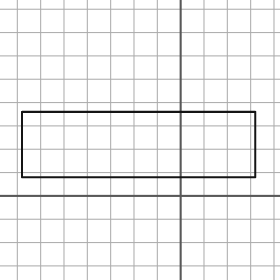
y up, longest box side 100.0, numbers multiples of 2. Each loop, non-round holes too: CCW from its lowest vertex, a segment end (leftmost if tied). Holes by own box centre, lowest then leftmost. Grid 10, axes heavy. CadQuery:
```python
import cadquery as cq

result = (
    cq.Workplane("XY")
    .moveTo(-68.0, 8.0)
    .lineTo(32.0, 8.0)
    .lineTo(32.0, 36.0)
    .lineTo(-68.0, 36.0)
    .close()
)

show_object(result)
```